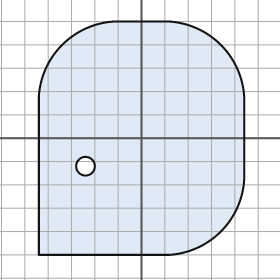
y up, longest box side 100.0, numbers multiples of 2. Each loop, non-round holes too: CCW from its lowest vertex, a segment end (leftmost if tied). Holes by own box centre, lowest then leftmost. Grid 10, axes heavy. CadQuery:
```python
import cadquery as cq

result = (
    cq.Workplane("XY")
    .moveTo(-44.0, -50.0)
    .lineTo(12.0, -50.0)
    .threePointArc((34.0, -40.0), (44.0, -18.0))
    .lineTo(44.0, 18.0)
    .threePointArc((34.0, 40.0), (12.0, 50.0))
    .lineTo(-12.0, 50.0)
    .threePointArc((-34.0, 40.0), (-44.0, 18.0))
    .close()
    .moveTo(-24.0, -12.0)
    .circle(4.0)
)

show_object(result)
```